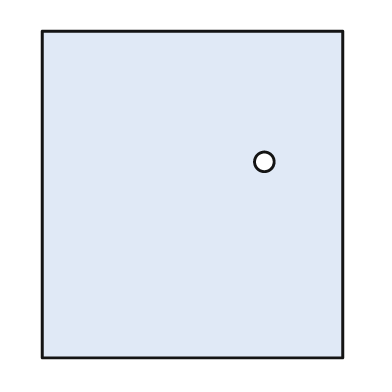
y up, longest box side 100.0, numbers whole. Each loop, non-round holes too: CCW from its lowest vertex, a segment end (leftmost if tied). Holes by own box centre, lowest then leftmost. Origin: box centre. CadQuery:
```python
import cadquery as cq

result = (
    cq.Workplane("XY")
    .moveTo(-46.0, -50.0)
    .lineTo(46.0, -50.0)
    .lineTo(46.0, 50.0)
    .lineTo(-46.0, 50.0)
    .close()
    .moveTo(22.0, 10.0)
    .circle(3.0)
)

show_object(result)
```